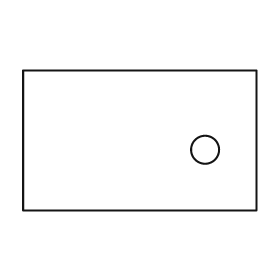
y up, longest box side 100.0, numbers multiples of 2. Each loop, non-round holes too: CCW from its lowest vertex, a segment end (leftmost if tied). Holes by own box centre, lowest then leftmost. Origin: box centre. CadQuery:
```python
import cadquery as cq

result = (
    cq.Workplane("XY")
    .moveTo(-50.0, -30.0)
    .lineTo(50.0, -30.0)
    .lineTo(50.0, 30.0)
    .lineTo(-50.0, 30.0)
    .close()
    .moveTo(28.0, -4.0)
    .circle(6.0)
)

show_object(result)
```